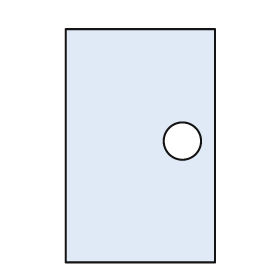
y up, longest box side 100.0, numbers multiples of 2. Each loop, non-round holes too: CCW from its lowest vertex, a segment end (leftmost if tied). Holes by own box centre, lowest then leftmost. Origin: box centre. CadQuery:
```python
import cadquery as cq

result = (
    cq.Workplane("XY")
    .moveTo(-32.0, -50.0)
    .lineTo(32.0, -50.0)
    .lineTo(32.0, 50.0)
    .lineTo(-32.0, 50.0)
    .close()
    .moveTo(18.0, 2.0)
    .circle(8.0)
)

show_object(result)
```